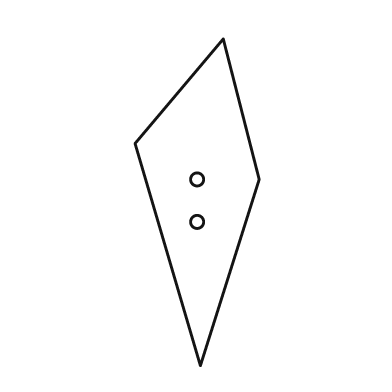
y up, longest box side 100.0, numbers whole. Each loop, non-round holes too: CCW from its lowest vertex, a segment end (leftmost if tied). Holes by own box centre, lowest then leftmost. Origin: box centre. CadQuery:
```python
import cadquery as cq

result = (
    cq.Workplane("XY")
    .moveTo(1.0, -50.0)
    .lineTo(19.0, 7.0)
    .lineTo(8.0, 50.0)
    .lineTo(-19.0, 18.0)
    .close()
    .moveTo(0.0, -6.0)
    .circle(2.0)
    .moveTo(0.0, 7.0)
    .circle(2.0)
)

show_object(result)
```